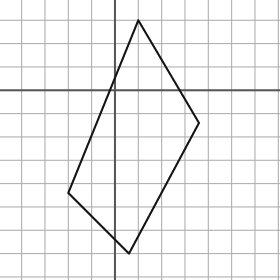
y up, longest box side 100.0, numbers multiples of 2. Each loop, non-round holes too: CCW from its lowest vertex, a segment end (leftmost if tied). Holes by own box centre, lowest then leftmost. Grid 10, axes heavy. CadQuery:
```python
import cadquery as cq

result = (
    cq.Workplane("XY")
    .moveTo(6.0, -70.0)
    .lineTo(36.0, -14.0)
    .lineTo(10.0, 30.0)
    .lineTo(-20.0, -44.0)
    .close()
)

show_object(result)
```